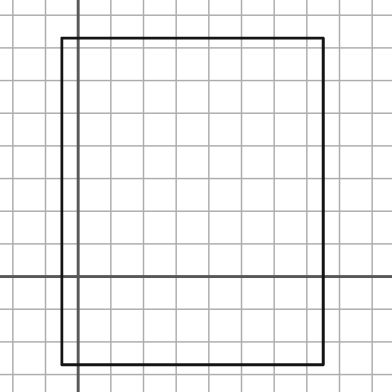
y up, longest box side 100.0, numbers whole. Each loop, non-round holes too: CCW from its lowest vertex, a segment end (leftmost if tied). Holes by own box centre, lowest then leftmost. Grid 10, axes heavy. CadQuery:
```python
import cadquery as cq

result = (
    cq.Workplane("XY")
    .moveTo(-5.0, -27.0)
    .lineTo(75.0, -27.0)
    .lineTo(75.0, 73.0)
    .lineTo(-5.0, 73.0)
    .close()
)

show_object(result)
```